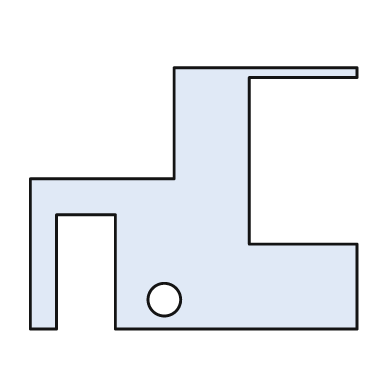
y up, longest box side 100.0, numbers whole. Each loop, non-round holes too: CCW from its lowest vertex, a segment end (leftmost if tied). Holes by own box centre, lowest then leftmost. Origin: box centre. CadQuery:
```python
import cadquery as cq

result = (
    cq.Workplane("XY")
    .moveTo(-50.0, -40.0)
    .lineTo(-42.0, -40.0)
    .lineTo(-42.0, -5.0)
    .lineTo(-24.0, -5.0)
    .lineTo(-24.0, -40.0)
    .lineTo(50.0, -40.0)
    .lineTo(50.0, -14.0)
    .lineTo(17.0, -14.0)
    .lineTo(17.0, 37.0)
    .lineTo(50.0, 37.0)
    .lineTo(50.0, 40.0)
    .lineTo(-6.0, 40.0)
    .lineTo(-6.0, 6.0)
    .lineTo(-50.0, 6.0)
    .close()
    .moveTo(-9.0, -31.0)
    .circle(5.0)
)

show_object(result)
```